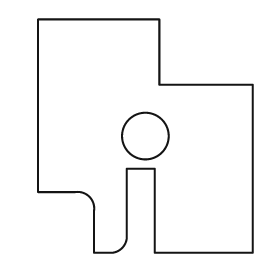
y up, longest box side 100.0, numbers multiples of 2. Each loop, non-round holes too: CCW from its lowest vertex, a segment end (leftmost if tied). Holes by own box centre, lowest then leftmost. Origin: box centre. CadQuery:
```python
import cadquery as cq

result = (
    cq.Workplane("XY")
    .moveTo(-22.0, -50.0)
    .lineTo(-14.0, -50.0)
    .threePointArc((-10.0, -48.0), (-8.0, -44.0))
    .lineTo(-8.0, -14.0)
    .lineTo(4.0, -14.0)
    .lineTo(4.0, -50.0)
    .lineTo(46.0, -50.0)
    .lineTo(46.0, 22.0)
    .lineTo(6.0, 22.0)
    .lineTo(6.0, 50.0)
    .lineTo(-46.0, 50.0)
    .lineTo(-46.0, -24.0)
    .lineTo(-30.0, -24.0)
    .threePointArc((-24.0, -26.0), (-22.0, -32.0))
    .close()
    .moveTo(0.0, 0.0)
    .circle(10.0)
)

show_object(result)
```